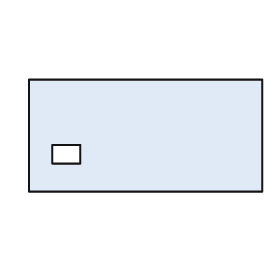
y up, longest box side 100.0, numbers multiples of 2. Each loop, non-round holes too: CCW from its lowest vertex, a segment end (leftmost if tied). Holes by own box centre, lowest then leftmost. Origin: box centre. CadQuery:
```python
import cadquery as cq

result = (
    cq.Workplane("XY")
    .moveTo(-50.0, -24.0)
    .lineTo(50.0, -24.0)
    .lineTo(50.0, 24.0)
    .lineTo(-50.0, 24.0)
    .close()
    .moveTo(-40.0, -12.0)
    .lineTo(-28.0, -12.0)
    .lineTo(-28.0, -4.0)
    .lineTo(-40.0, -4.0)
    .close()
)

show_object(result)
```